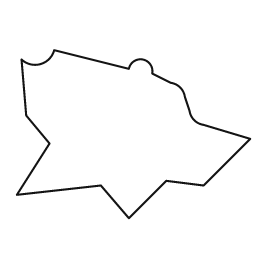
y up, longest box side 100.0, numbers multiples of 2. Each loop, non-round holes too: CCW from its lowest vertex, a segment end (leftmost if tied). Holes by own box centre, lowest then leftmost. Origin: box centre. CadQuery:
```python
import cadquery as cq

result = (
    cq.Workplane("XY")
    .moveTo(-2.0, -36.0)
    .lineTo(14.0, -20.0)
    .lineTo(30.0, -22.0)
    .lineTo(50.0, -2.0)
    .lineTo(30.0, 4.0)
    .threePointArc((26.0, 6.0), (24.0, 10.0))
    .lineTo(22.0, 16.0)
    .threePointArc((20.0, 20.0), (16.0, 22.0))
    .lineTo(8.0, 26.0)
    .threePointArc((4.0, 32.0), (-2.0, 28.0))
    .lineTo(-34.0, 36.0)
    .threePointArc((-40.0, 30.0), (-48.0, 32.0))
    .lineTo(-46.0, 8.0)
    .lineTo(-36.0, -4.0)
    .lineTo(-50.0, -26.0)
    .lineTo(-14.0, -22.0)
    .close()
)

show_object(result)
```